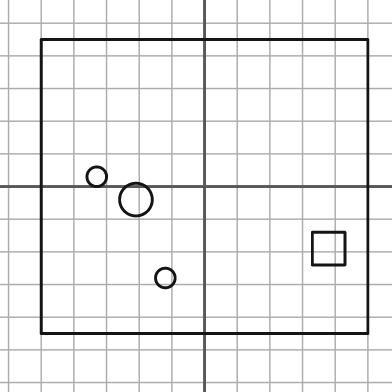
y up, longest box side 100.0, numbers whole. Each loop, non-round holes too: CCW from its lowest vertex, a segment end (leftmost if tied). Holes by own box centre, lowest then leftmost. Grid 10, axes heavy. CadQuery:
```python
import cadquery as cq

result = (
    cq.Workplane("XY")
    .moveTo(-50.0, -45.0)
    .lineTo(50.0, -45.0)
    .lineTo(50.0, 45.0)
    .lineTo(-50.0, 45.0)
    .close()
    .moveTo(-12.0, -28.0)
    .circle(3.0)
    .moveTo(33.0, -24.0)
    .lineTo(43.0, -24.0)
    .lineTo(43.0, -14.0)
    .lineTo(33.0, -14.0)
    .close()
    .moveTo(-21.0, -4.0)
    .circle(5.0)
    .moveTo(-33.0, 3.0)
    .circle(3.0)
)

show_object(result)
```